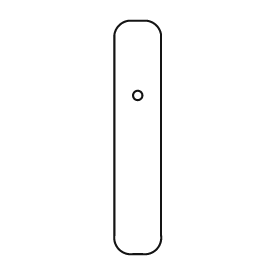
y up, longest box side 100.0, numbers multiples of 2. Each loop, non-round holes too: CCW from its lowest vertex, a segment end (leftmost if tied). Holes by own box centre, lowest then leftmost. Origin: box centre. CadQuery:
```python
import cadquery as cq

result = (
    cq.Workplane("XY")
    .moveTo(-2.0, -50.0)
    .lineTo(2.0, -50.0)
    .threePointArc((8.0, -48.0), (10.0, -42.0))
    .lineTo(10.0, 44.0)
    .threePointArc((8.0, 48.0), (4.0, 50.0))
    .lineTo(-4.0, 50.0)
    .threePointArc((-8.0, 48.0), (-10.0, 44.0))
    .lineTo(-10.0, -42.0)
    .threePointArc((-8.0, -48.0), (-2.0, -50.0))
    .close()
    .moveTo(0.0, 18.0)
    .circle(2.0)
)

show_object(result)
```